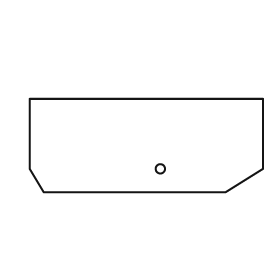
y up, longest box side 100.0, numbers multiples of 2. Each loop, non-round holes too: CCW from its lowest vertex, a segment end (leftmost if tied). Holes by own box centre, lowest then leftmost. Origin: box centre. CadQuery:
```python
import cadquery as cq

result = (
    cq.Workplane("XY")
    .moveTo(-44.0, -20.0)
    .lineTo(34.0, -20.0)
    .lineTo(50.0, -10.0)
    .lineTo(50.0, 20.0)
    .lineTo(-50.0, 20.0)
    .lineTo(-50.0, -10.0)
    .close()
    .moveTo(6.0, -10.0)
    .circle(2.0)
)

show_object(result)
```